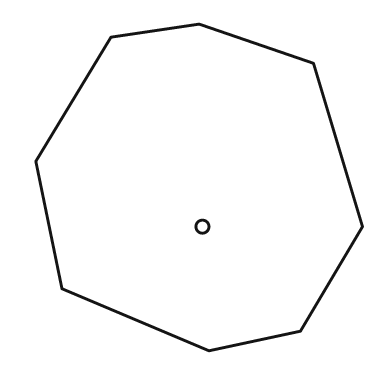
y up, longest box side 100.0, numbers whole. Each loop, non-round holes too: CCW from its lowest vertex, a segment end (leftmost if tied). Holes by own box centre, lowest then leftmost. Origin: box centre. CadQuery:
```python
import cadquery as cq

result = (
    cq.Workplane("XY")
    .moveTo(3.0, -50.0)
    .lineTo(31.0, -44.0)
    .lineTo(50.0, -12.0)
    .lineTo(35.0, 38.0)
    .lineTo(0.0, 50.0)
    .lineTo(-27.0, 46.0)
    .lineTo(-50.0, 8.0)
    .lineTo(-42.0, -31.0)
    .close()
    .moveTo(1.0, -12.0)
    .circle(2.0)
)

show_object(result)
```